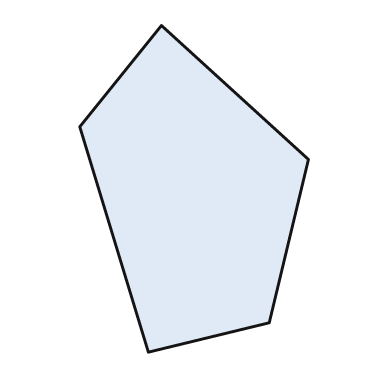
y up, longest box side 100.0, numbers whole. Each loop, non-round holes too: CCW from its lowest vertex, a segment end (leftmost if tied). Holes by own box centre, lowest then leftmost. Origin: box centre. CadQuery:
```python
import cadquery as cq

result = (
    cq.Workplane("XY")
    .moveTo(-14.0, -50.0)
    .lineTo(23.0, -41.0)
    .lineTo(35.0, 9.0)
    .lineTo(-10.0, 50.0)
    .lineTo(-35.0, 19.0)
    .close()
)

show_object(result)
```